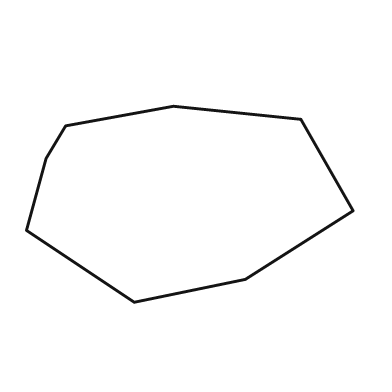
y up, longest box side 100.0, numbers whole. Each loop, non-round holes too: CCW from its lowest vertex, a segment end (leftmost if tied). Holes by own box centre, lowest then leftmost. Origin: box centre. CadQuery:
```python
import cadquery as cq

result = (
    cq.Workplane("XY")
    .moveTo(-17.0, -30.0)
    .lineTo(17.0, -23.0)
    .lineTo(50.0, -2.0)
    .lineTo(34.0, 26.0)
    .lineTo(-5.0, 30.0)
    .lineTo(-38.0, 24.0)
    .lineTo(-44.0, 14.0)
    .lineTo(-50.0, -8.0)
    .close()
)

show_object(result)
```